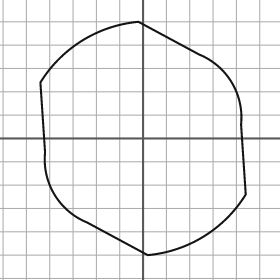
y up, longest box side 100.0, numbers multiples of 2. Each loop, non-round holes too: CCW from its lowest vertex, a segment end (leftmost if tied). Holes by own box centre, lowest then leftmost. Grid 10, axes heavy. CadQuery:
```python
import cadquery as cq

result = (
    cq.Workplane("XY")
    .moveTo(2.0, -50.0)
    .threePointArc((26.0, -42.0), (44.0, -24.0))
    .lineTo(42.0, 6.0)
    .threePointArc((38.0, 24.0), (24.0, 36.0))
    .lineTo(-2.0, 50.0)
    .threePointArc((-26.0, 42.0), (-44.0, 24.0))
    .lineTo(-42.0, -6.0)
    .threePointArc((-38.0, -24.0), (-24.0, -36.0))
    .close()
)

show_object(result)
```